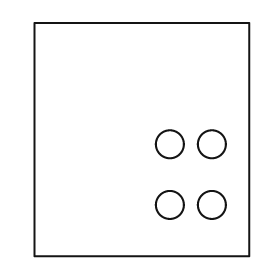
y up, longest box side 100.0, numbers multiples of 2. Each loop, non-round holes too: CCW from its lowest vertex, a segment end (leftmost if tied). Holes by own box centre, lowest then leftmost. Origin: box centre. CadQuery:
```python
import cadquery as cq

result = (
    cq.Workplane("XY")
    .moveTo(-46.0, -50.0)
    .lineTo(46.0, -50.0)
    .lineTo(46.0, 50.0)
    .lineTo(-46.0, 50.0)
    .close()
    .moveTo(12.0, -28.0)
    .circle(6.0)
    .moveTo(30.0, -28.0)
    .circle(6.0)
    .moveTo(12.0, -2.0)
    .circle(6.0)
    .moveTo(30.0, -2.0)
    .circle(6.0)
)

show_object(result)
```